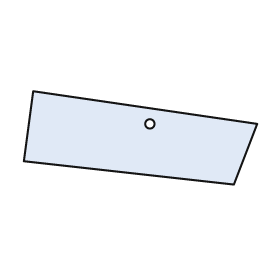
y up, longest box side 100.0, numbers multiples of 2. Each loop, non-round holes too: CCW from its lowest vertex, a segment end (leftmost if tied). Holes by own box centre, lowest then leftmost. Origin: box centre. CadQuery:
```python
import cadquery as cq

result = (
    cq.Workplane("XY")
    .moveTo(40.0, -20.0)
    .lineTo(50.0, 6.0)
    .lineTo(-46.0, 20.0)
    .lineTo(-50.0, -10.0)
    .close()
    .moveTo(4.0, 6.0)
    .circle(2.0)
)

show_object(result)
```